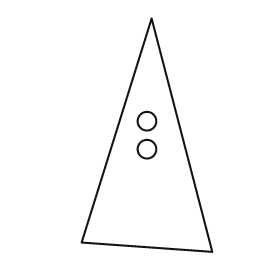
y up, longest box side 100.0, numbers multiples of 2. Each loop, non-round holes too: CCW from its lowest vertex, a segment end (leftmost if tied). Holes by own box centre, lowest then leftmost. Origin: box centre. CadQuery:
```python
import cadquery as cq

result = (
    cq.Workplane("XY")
    .moveTo(28.0, -50.0)
    .lineTo(2.0, 50.0)
    .lineTo(-28.0, -46.0)
    .close()
    .moveTo(0.0, -6.0)
    .circle(4.0)
    .moveTo(0.0, 6.0)
    .circle(4.0)
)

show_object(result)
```